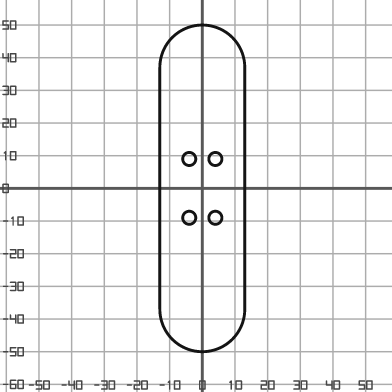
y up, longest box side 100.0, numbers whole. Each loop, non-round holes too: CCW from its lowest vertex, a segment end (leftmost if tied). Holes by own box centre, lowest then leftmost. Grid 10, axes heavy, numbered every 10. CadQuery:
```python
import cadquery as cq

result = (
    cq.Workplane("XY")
    .moveTo(-13.0, -37.0)
    .threePointArc((0.0, -50.0), (13.0, -37.0))
    .lineTo(13.0, 37.0)
    .threePointArc((0.0, 50.0), (-13.0, 37.0))
    .close()
    .moveTo(-4.0, -9.0)
    .circle(2.0)
    .moveTo(4.0, -9.0)
    .circle(2.0)
    .moveTo(-4.0, 9.0)
    .circle(2.0)
    .moveTo(4.0, 9.0)
    .circle(2.0)
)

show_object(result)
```